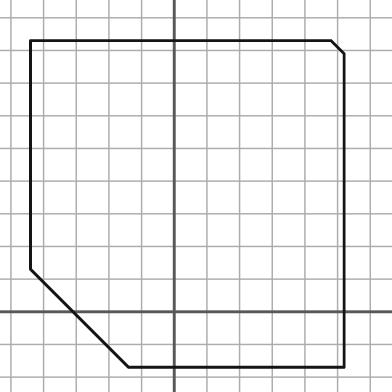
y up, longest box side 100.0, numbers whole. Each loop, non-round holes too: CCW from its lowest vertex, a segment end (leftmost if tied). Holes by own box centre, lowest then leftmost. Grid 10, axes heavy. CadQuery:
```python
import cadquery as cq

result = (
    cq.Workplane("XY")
    .moveTo(-14.0, -17.0)
    .lineTo(52.0, -17.0)
    .lineTo(52.0, 79.0)
    .lineTo(48.0, 83.0)
    .lineTo(-44.0, 83.0)
    .lineTo(-44.0, 13.0)
    .close()
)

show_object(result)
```